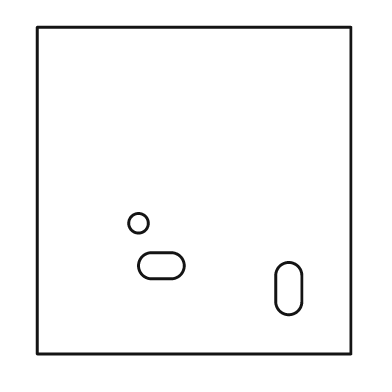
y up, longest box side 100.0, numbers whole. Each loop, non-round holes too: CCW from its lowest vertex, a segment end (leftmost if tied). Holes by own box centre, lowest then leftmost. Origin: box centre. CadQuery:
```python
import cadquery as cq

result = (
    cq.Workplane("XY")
    .moveTo(-48.0, -50.0)
    .lineTo(48.0, -50.0)
    .lineTo(48.0, 50.0)
    .lineTo(-48.0, 50.0)
    .close()
    .moveTo(25.0, -34.0)
    .threePointArc((29.0, -38.0), (33.0, -34.0))
    .lineTo(33.0, -26.0)
    .threePointArc((29.0, -22.0), (25.0, -26.0))
    .close()
    .moveTo(-13.0, -27.0)
    .lineTo(-7.0, -27.0)
    .threePointArc((-3.0, -23.0), (-7.0, -19.0))
    .lineTo(-13.0, -19.0)
    .threePointArc((-17.0, -23.0), (-13.0, -27.0))
    .close()
    .moveTo(-17.0, -10.0)
    .circle(3.0)
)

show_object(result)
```